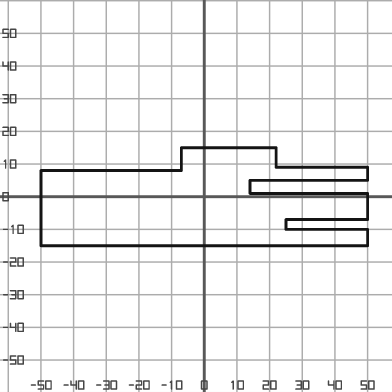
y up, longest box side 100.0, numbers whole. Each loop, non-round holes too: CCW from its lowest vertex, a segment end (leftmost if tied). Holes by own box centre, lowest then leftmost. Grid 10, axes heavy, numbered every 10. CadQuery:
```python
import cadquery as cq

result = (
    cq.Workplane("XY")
    .moveTo(-50.0, -15.0)
    .lineTo(50.0, -15.0)
    .lineTo(50.0, -10.0)
    .lineTo(25.0, -10.0)
    .lineTo(25.0, -7.0)
    .lineTo(50.0, -7.0)
    .lineTo(50.0, 1.0)
    .lineTo(14.0, 1.0)
    .lineTo(14.0, 5.0)
    .lineTo(50.0, 5.0)
    .lineTo(50.0, 9.0)
    .lineTo(22.0, 9.0)
    .lineTo(22.0, 15.0)
    .lineTo(-7.0, 15.0)
    .lineTo(-7.0, 8.0)
    .lineTo(-50.0, 8.0)
    .close()
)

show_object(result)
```